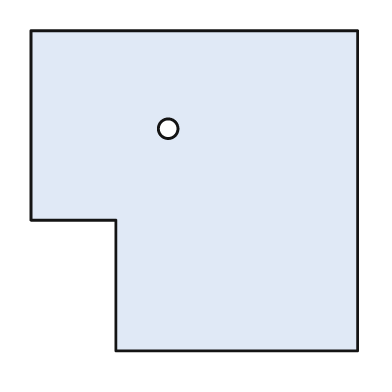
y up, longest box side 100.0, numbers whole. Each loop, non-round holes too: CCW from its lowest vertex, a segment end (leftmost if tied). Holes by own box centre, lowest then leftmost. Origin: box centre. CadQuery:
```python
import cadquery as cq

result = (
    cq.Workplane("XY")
    .moveTo(-24.0, -49.0)
    .lineTo(50.0, -49.0)
    .lineTo(50.0, 49.0)
    .lineTo(-50.0, 49.0)
    .lineTo(-50.0, -9.0)
    .lineTo(-24.0, -9.0)
    .close()
    .moveTo(-8.0, 19.0)
    .circle(3.0)
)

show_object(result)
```